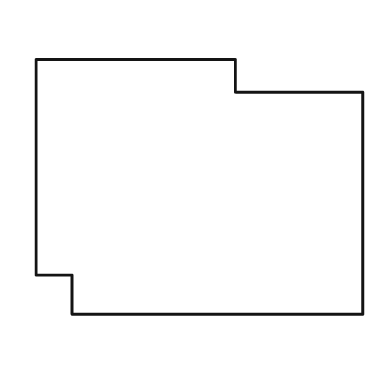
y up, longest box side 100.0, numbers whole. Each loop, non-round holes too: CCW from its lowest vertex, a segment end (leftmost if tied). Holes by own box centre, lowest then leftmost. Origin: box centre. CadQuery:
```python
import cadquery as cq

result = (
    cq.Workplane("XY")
    .moveTo(-39.0, -39.0)
    .lineTo(50.0, -39.0)
    .lineTo(50.0, 29.0)
    .lineTo(11.0, 29.0)
    .lineTo(11.0, 39.0)
    .lineTo(-50.0, 39.0)
    .lineTo(-50.0, -27.0)
    .lineTo(-39.0, -27.0)
    .close()
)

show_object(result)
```